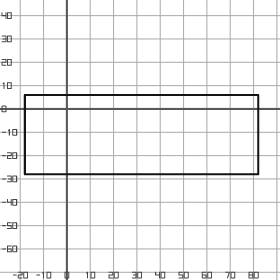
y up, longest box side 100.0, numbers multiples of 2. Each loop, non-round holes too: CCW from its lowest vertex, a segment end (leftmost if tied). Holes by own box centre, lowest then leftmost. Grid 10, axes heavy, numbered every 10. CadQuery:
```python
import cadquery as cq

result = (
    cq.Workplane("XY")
    .moveTo(-18.0, -28.0)
    .lineTo(82.0, -28.0)
    .lineTo(82.0, 6.0)
    .lineTo(-18.0, 6.0)
    .close()
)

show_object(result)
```